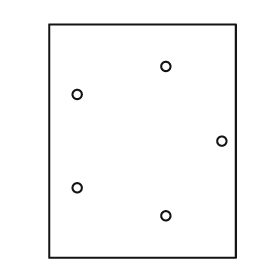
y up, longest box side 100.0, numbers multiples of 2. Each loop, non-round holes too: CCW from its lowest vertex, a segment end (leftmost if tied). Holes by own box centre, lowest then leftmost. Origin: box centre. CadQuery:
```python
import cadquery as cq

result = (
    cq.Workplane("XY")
    .moveTo(-40.0, -50.0)
    .lineTo(40.0, -50.0)
    .lineTo(40.0, 50.0)
    .lineTo(-40.0, 50.0)
    .close()
    .moveTo(10.0, -32.0)
    .circle(2.0)
    .moveTo(-28.0, -20.0)
    .circle(2.0)
    .moveTo(34.0, 0.0)
    .circle(2.0)
    .moveTo(-28.0, 20.0)
    .circle(2.0)
    .moveTo(10.0, 32.0)
    .circle(2.0)
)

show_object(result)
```